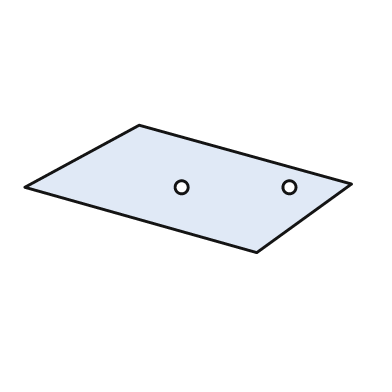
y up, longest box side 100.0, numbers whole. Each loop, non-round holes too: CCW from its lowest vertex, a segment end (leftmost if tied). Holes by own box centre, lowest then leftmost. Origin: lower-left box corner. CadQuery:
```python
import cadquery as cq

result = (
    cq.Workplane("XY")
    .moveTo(71.0, 0.0)
    .lineTo(100.0, 21.0)
    .lineTo(35.0, 39.0)
    .lineTo(0.0, 20.0)
    .close()
    .moveTo(48.0, 20.0)
    .circle(2.0)
    .moveTo(81.0, 20.0)
    .circle(2.0)
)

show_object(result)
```